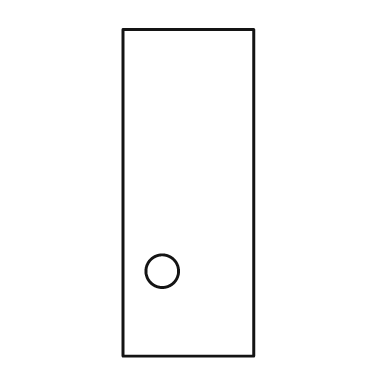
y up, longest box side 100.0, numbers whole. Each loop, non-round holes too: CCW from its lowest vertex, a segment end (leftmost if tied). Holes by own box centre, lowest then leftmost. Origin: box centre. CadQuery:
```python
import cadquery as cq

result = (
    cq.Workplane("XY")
    .moveTo(-20.0, -50.0)
    .lineTo(20.0, -50.0)
    .lineTo(20.0, 50.0)
    .lineTo(-20.0, 50.0)
    .close()
    .moveTo(-8.0, -24.0)
    .circle(5.0)
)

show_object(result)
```